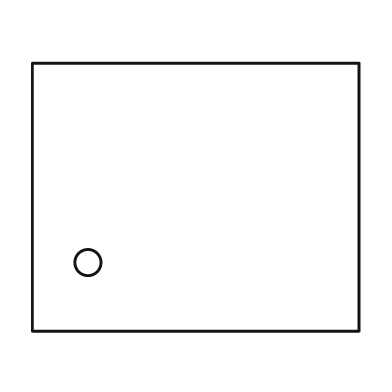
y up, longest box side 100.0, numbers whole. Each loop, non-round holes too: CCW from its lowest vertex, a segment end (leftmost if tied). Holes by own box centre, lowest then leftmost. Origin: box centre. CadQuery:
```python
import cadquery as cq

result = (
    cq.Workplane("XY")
    .moveTo(-50.0, -41.0)
    .lineTo(50.0, -41.0)
    .lineTo(50.0, 41.0)
    .lineTo(-50.0, 41.0)
    .close()
    .moveTo(-33.0, -20.0)
    .circle(4.0)
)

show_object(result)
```